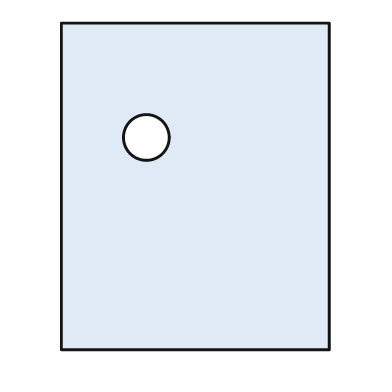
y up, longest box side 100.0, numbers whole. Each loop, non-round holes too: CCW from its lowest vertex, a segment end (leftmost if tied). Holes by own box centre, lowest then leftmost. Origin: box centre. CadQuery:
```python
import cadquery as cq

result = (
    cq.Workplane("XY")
    .moveTo(-41.0, -50.0)
    .lineTo(41.0, -50.0)
    .lineTo(41.0, 50.0)
    .lineTo(-41.0, 50.0)
    .close()
    .moveTo(-15.0, 15.0)
    .circle(7.0)
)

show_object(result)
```